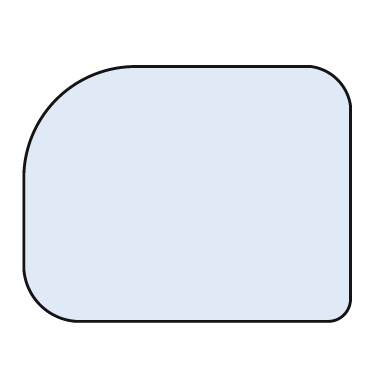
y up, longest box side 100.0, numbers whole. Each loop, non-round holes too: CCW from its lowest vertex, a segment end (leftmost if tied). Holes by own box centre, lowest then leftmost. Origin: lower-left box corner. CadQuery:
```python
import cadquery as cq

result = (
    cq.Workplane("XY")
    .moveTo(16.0, 0.0)
    .lineTo(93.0, 0.0)
    .threePointArc((98.0, 2.0), (100.0, 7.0))
    .lineTo(100.0, 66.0)
    .threePointArc((96.0, 74.0), (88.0, 78.0))
    .lineTo(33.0, 78.0)
    .threePointArc((10.0, 68.0), (0.0, 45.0))
    .lineTo(0.0, 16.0)
    .threePointArc((5.0, 5.0), (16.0, 0.0))
    .close()
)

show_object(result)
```